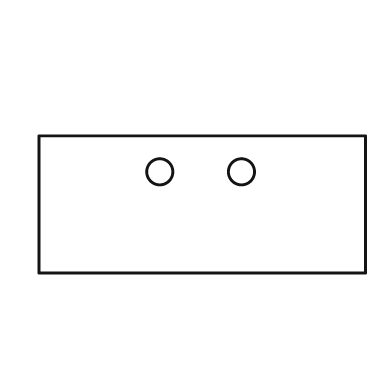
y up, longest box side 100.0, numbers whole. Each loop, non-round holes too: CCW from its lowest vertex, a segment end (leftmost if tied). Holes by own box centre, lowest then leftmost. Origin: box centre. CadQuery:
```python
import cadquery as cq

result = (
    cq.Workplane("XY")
    .moveTo(-50.0, -21.0)
    .lineTo(50.0, -21.0)
    .lineTo(50.0, 21.0)
    .lineTo(-50.0, 21.0)
    .close()
    .moveTo(-13.0, 10.0)
    .circle(4.0)
    .moveTo(12.0, 10.0)
    .circle(4.0)
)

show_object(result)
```